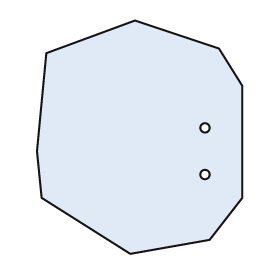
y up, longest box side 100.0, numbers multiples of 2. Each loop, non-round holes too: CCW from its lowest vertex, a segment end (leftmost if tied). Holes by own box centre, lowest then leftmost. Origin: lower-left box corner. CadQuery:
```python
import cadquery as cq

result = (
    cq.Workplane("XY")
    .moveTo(40.0, 0.0)
    .lineTo(74.0, 6.0)
    .lineTo(88.0, 24.0)
    .lineTo(88.0, 72.0)
    .lineTo(78.0, 88.0)
    .lineTo(42.0, 100.0)
    .lineTo(4.0, 86.0)
    .lineTo(0.0, 44.0)
    .lineTo(2.0, 24.0)
    .close()
    .moveTo(72.0, 34.0)
    .circle(2.0)
    .moveTo(72.0, 54.0)
    .circle(2.0)
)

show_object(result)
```